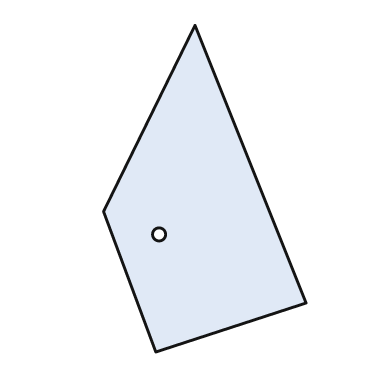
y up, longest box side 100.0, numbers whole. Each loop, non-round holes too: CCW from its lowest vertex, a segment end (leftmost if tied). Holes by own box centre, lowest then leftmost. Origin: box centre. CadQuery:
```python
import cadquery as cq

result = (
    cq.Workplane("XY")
    .moveTo(-15.0, -50.0)
    .lineTo(31.0, -35.0)
    .lineTo(-3.0, 50.0)
    .lineTo(-31.0, -7.0)
    .close()
    .moveTo(-14.0, -14.0)
    .circle(2.0)
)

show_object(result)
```